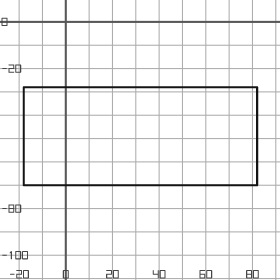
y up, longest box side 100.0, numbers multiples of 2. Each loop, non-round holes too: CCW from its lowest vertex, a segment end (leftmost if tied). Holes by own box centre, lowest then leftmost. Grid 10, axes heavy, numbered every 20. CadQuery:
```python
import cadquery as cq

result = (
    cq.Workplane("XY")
    .moveTo(-18.0, -70.0)
    .lineTo(82.0, -70.0)
    .lineTo(82.0, -28.0)
    .lineTo(-18.0, -28.0)
    .close()
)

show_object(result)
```